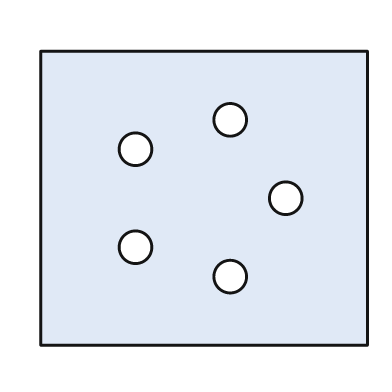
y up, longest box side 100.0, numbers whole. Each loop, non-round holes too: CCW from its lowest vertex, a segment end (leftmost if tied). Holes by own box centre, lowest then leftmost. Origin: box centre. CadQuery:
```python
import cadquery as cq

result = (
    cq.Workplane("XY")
    .moveTo(-50.0, -45.0)
    .lineTo(50.0, -45.0)
    .lineTo(50.0, 45.0)
    .lineTo(-50.0, 45.0)
    .close()
    .moveTo(8.0, -24.0)
    .circle(5.0)
    .moveTo(-21.0, -15.0)
    .circle(5.0)
    .moveTo(25.0, 0.0)
    .circle(5.0)
    .moveTo(-21.0, 15.0)
    .circle(5.0)
    .moveTo(8.0, 24.0)
    .circle(5.0)
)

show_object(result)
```